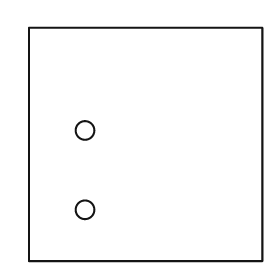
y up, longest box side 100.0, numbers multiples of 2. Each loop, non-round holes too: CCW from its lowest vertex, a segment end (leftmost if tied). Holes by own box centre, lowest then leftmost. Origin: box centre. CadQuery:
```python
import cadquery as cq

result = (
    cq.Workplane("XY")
    .moveTo(-50.0, -50.0)
    .lineTo(50.0, -50.0)
    .lineTo(50.0, 50.0)
    .lineTo(-50.0, 50.0)
    .close()
    .moveTo(-26.0, -28.0)
    .circle(4.0)
    .moveTo(-26.0, 6.0)
    .circle(4.0)
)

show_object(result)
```